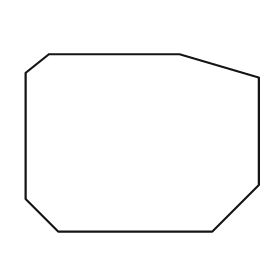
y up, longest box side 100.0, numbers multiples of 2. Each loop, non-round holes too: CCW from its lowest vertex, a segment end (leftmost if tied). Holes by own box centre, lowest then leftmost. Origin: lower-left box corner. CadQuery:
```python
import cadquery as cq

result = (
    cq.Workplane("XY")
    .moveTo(14.0, 0.0)
    .lineTo(80.0, 0.0)
    .lineTo(100.0, 20.0)
    .lineTo(100.0, 66.0)
    .lineTo(66.0, 76.0)
    .lineTo(10.0, 76.0)
    .lineTo(0.0, 68.0)
    .lineTo(0.0, 14.0)
    .close()
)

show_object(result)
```